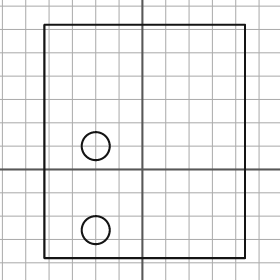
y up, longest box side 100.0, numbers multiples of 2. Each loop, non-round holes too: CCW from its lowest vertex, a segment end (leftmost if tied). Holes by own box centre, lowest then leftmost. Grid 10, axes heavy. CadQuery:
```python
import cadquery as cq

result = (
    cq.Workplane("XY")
    .moveTo(-42.0, -38.0)
    .lineTo(44.0, -38.0)
    .lineTo(44.0, 62.0)
    .lineTo(-42.0, 62.0)
    .close()
    .moveTo(-20.0, -26.0)
    .circle(6.0)
    .moveTo(-20.0, 10.0)
    .circle(6.0)
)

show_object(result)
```